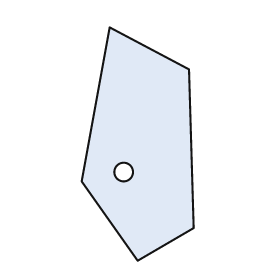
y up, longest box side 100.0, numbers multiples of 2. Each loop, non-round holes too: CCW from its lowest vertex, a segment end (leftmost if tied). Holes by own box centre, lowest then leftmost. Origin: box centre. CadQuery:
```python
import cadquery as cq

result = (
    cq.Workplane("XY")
    .moveTo(0.0, -50.0)
    .lineTo(24.0, -36.0)
    .lineTo(22.0, 32.0)
    .lineTo(-12.0, 50.0)
    .lineTo(-24.0, -16.0)
    .close()
    .moveTo(-6.0, -12.0)
    .circle(4.0)
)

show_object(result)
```